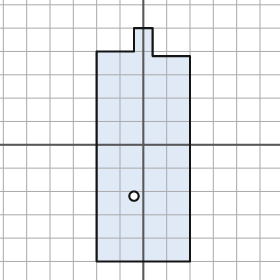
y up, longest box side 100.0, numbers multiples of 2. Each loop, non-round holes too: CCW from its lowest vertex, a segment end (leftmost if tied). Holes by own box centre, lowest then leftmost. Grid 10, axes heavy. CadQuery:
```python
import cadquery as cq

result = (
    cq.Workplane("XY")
    .moveTo(-20.0, -50.0)
    .lineTo(20.0, -50.0)
    .lineTo(20.0, 38.0)
    .lineTo(4.0, 38.0)
    .lineTo(4.0, 50.0)
    .lineTo(-4.0, 50.0)
    .lineTo(-4.0, 40.0)
    .lineTo(-20.0, 40.0)
    .close()
    .moveTo(-4.0, -22.0)
    .circle(2.0)
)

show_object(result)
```